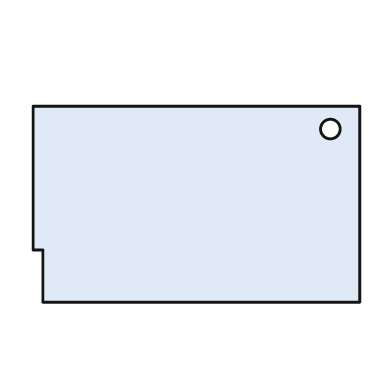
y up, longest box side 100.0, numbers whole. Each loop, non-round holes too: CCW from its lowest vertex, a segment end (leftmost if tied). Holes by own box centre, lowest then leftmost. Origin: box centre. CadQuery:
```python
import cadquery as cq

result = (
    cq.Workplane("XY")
    .moveTo(-47.0, -30.0)
    .lineTo(50.0, -30.0)
    .lineTo(50.0, 30.0)
    .lineTo(-50.0, 30.0)
    .lineTo(-50.0, -14.0)
    .lineTo(-47.0, -14.0)
    .close()
    .moveTo(41.0, 23.0)
    .circle(3.0)
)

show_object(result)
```